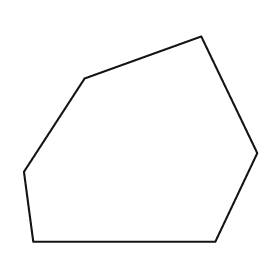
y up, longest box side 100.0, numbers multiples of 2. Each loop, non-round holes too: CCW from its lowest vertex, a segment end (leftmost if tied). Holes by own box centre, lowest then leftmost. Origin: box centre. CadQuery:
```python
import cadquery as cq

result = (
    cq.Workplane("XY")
    .moveTo(-46.0, -44.0)
    .lineTo(32.0, -44.0)
    .lineTo(50.0, -6.0)
    .lineTo(26.0, 44.0)
    .lineTo(-24.0, 26.0)
    .lineTo(-50.0, -14.0)
    .close()
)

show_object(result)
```